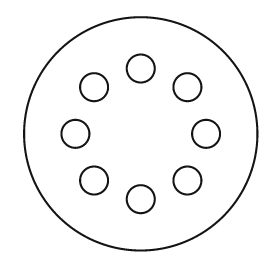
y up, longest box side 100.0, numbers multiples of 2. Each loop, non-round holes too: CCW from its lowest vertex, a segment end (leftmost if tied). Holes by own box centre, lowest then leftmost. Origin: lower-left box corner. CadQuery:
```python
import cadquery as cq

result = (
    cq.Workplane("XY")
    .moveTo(50.0, 50.0)
    .circle(50.0)
    .moveTo(50.0, 22.0)
    .circle(6.0)
    .moveTo(30.0, 30.0)
    .circle(6.0)
    .moveTo(70.0, 30.0)
    .circle(6.0)
    .moveTo(22.0, 50.0)
    .circle(6.0)
    .moveTo(78.0, 50.0)
    .circle(6.0)
    .moveTo(30.0, 70.0)
    .circle(6.0)
    .moveTo(70.0, 70.0)
    .circle(6.0)
    .moveTo(50.0, 78.0)
    .circle(6.0)
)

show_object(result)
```